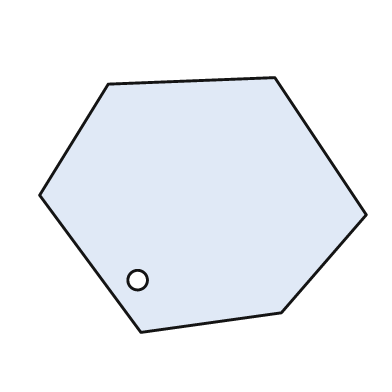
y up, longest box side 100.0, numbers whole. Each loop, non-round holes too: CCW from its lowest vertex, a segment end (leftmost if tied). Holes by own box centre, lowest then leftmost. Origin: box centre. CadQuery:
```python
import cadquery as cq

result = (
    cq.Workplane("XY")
    .moveTo(-19.0, -39.0)
    .lineTo(24.0, -33.0)
    .lineTo(50.0, -3.0)
    .lineTo(22.0, 39.0)
    .lineTo(-29.0, 37.0)
    .lineTo(-50.0, 3.0)
    .close()
    .moveTo(-20.0, -23.0)
    .circle(3.0)
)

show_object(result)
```